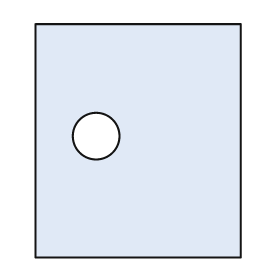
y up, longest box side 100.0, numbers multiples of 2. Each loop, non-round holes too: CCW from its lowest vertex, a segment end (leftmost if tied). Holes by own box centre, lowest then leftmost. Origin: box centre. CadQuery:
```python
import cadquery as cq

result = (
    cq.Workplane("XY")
    .moveTo(-44.0, -50.0)
    .lineTo(44.0, -50.0)
    .lineTo(44.0, 50.0)
    .lineTo(-44.0, 50.0)
    .close()
    .moveTo(-18.0, 2.0)
    .circle(10.0)
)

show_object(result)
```